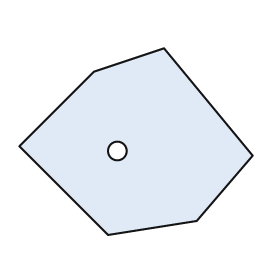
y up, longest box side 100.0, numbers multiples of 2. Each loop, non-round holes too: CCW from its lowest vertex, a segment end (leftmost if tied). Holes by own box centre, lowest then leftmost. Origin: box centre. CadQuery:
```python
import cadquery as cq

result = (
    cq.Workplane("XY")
    .moveTo(-12.0, -40.0)
    .lineTo(26.0, -34.0)
    .lineTo(50.0, -6.0)
    .lineTo(12.0, 40.0)
    .lineTo(-18.0, 30.0)
    .lineTo(-50.0, -2.0)
    .close()
    .moveTo(-8.0, -4.0)
    .circle(4.0)
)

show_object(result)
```